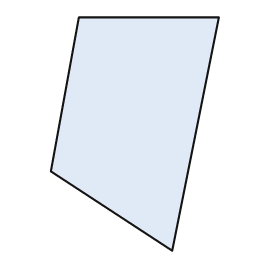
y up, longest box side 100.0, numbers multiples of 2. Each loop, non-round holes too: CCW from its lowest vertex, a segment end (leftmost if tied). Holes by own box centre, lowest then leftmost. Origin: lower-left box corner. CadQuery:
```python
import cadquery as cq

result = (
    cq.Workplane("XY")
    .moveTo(52.0, 0.0)
    .lineTo(72.0, 100.0)
    .lineTo(12.0, 100.0)
    .lineTo(0.0, 34.0)
    .close()
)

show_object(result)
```